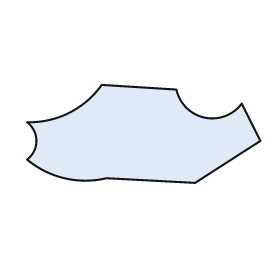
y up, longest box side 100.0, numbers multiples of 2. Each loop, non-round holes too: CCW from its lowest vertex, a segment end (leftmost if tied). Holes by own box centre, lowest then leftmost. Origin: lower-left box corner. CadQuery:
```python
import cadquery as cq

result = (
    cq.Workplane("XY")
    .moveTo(72.0, 0.0)
    .lineTo(100.0, 18.0)
    .lineTo(92.0, 34.0)
    .threePointArc((76.0, 28.0), (64.0, 40.0))
    .lineTo(32.0, 42.0)
    .threePointArc((18.0, 30.0), (0.0, 26.0))
    .threePointArc((4.0, 18.0), (0.0, 10.0))
    .threePointArc((16.0, 2.0), (34.0, 2.0))
    .close()
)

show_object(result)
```